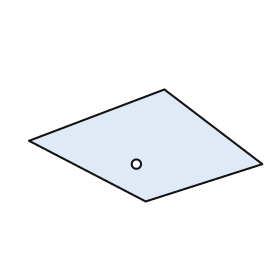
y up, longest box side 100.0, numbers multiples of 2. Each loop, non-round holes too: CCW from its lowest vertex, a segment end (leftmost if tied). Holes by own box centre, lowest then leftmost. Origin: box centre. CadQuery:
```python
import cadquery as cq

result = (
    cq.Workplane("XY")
    .moveTo(0.0, -24.0)
    .lineTo(50.0, -8.0)
    .lineTo(8.0, 24.0)
    .lineTo(-50.0, 2.0)
    .close()
    .moveTo(-4.0, -8.0)
    .circle(2.0)
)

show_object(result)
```